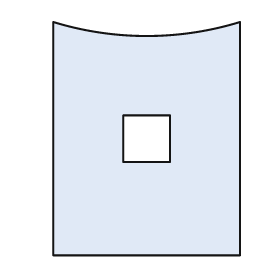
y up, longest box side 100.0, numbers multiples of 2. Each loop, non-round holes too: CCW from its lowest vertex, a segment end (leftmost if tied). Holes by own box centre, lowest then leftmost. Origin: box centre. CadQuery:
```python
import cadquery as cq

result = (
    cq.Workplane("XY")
    .moveTo(-40.0, -50.0)
    .lineTo(40.0, -50.0)
    .lineTo(40.0, 50.0)
    .threePointArc((0.0, 44.0), (-40.0, 50.0))
    .close()
    .moveTo(-10.0, -10.0)
    .lineTo(10.0, -10.0)
    .lineTo(10.0, 10.0)
    .lineTo(-10.0, 10.0)
    .close()
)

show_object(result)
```